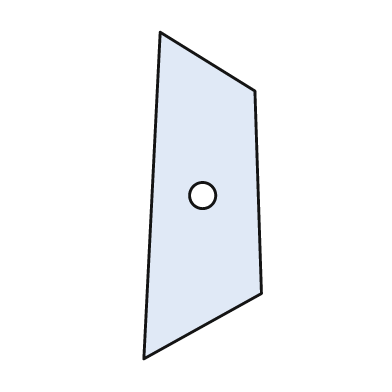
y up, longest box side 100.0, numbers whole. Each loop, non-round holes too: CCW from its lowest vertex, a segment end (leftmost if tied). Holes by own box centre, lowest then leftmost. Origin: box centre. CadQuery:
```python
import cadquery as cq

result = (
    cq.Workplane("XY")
    .moveTo(-18.0, -50.0)
    .lineTo(18.0, -30.0)
    .lineTo(16.0, 32.0)
    .lineTo(-13.0, 50.0)
    .close()
    .moveTo(0.0, 0.0)
    .circle(4.0)
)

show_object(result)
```